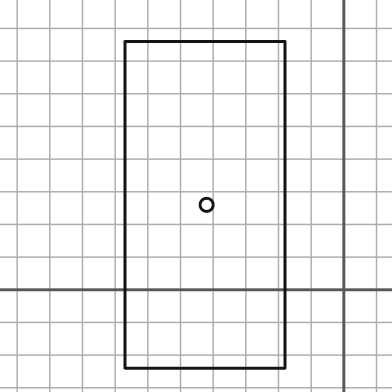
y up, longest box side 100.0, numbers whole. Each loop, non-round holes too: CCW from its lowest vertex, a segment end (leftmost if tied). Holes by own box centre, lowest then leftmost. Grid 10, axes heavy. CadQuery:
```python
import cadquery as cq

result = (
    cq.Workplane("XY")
    .moveTo(-67.0, -24.0)
    .lineTo(-18.0, -24.0)
    .lineTo(-18.0, 76.0)
    .lineTo(-67.0, 76.0)
    .close()
    .moveTo(-42.0, 26.0)
    .circle(2.0)
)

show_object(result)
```